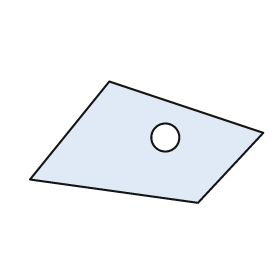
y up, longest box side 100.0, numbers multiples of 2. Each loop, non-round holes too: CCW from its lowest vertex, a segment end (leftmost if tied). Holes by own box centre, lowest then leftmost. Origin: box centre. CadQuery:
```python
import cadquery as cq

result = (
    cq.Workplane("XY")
    .moveTo(22.0, -26.0)
    .lineTo(50.0, 4.0)
    .lineTo(-16.0, 26.0)
    .lineTo(-50.0, -16.0)
    .close()
    .moveTo(8.0, 2.0)
    .circle(6.0)
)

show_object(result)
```